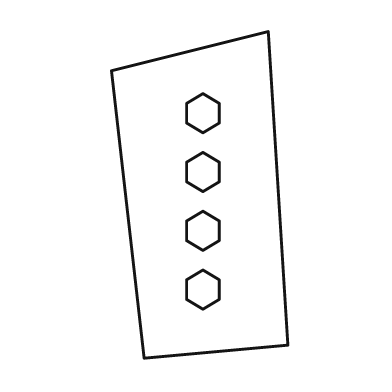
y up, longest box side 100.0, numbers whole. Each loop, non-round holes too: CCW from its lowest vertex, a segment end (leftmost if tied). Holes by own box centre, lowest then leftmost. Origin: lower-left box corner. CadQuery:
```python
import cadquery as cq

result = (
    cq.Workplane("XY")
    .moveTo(10.0, 0.0)
    .lineTo(54.0, 4.0)
    .lineTo(48.0, 100.0)
    .lineTo(0.0, 88.0)
    .close()
    .moveTo(28.0, 15.0)
    .lineTo(33.0, 18.0)
    .lineTo(33.0, 24.0)
    .lineTo(28.0, 27.0)
    .lineTo(23.0, 24.0)
    .lineTo(23.0, 18.0)
    .close()
    .moveTo(28.0, 33.0)
    .lineTo(33.0, 36.0)
    .lineTo(33.0, 42.0)
    .lineTo(28.0, 45.0)
    .lineTo(23.0, 42.0)
    .lineTo(23.0, 36.0)
    .close()
    .moveTo(28.0, 51.0)
    .lineTo(33.0, 54.0)
    .lineTo(33.0, 60.0)
    .lineTo(28.0, 63.0)
    .lineTo(23.0, 60.0)
    .lineTo(23.0, 54.0)
    .close()
    .moveTo(28.0, 69.0)
    .lineTo(33.0, 72.0)
    .lineTo(33.0, 78.0)
    .lineTo(28.0, 81.0)
    .lineTo(23.0, 78.0)
    .lineTo(23.0, 72.0)
    .close()
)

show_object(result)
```